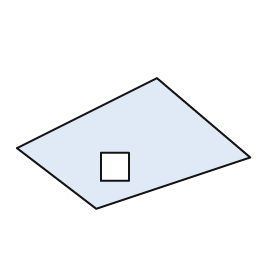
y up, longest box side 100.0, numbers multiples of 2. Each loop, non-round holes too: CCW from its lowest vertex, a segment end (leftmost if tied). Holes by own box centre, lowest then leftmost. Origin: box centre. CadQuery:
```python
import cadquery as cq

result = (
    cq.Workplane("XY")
    .moveTo(-16.0, -28.0)
    .lineTo(50.0, -6.0)
    .lineTo(10.0, 28.0)
    .lineTo(-50.0, -2.0)
    .close()
    .moveTo(-14.0, -16.0)
    .lineTo(-2.0, -16.0)
    .lineTo(-2.0, -4.0)
    .lineTo(-14.0, -4.0)
    .close()
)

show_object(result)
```